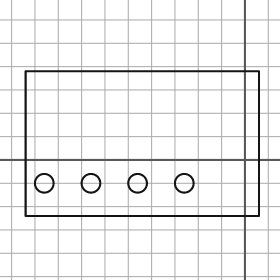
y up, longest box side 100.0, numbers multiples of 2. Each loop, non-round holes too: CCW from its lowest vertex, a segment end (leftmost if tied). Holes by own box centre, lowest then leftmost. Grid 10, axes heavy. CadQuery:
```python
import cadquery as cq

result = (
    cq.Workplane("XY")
    .moveTo(-94.0, -24.0)
    .lineTo(6.0, -24.0)
    .lineTo(6.0, 38.0)
    .lineTo(-94.0, 38.0)
    .close()
    .moveTo(-86.0, -10.0)
    .circle(4.0)
    .moveTo(-66.0, -10.0)
    .circle(4.0)
    .moveTo(-46.0, -10.0)
    .circle(4.0)
    .moveTo(-26.0, -10.0)
    .circle(4.0)
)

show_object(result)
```